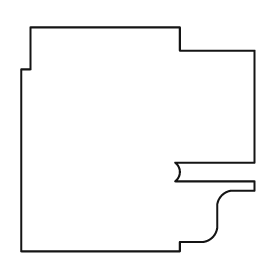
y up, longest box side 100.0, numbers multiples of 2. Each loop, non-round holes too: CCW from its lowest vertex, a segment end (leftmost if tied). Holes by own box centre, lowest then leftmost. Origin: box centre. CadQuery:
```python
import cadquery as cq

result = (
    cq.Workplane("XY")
    .moveTo(-50.0, -48.0)
    .lineTo(18.0, -48.0)
    .lineTo(18.0, -44.0)
    .lineTo(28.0, -44.0)
    .threePointArc((32.0, -42.0), (34.0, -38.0))
    .lineTo(34.0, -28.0)
    .threePointArc((36.0, -24.0), (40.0, -22.0))
    .lineTo(50.0, -22.0)
    .lineTo(50.0, -18.0)
    .lineTo(16.0, -18.0)
    .threePointArc((18.0, -14.0), (16.0, -10.0))
    .lineTo(50.0, -10.0)
    .lineTo(50.0, 38.0)
    .lineTo(18.0, 38.0)
    .lineTo(18.0, 48.0)
    .lineTo(-46.0, 48.0)
    .lineTo(-46.0, 30.0)
    .lineTo(-50.0, 30.0)
    .close()
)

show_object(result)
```